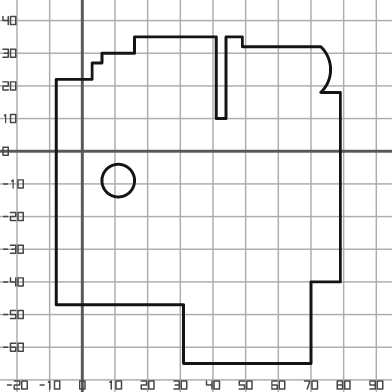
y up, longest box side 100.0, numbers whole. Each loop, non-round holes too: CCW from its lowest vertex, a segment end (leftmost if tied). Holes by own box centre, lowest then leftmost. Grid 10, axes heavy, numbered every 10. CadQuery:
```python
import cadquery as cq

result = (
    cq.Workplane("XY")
    .moveTo(31.0, -65.0)
    .lineTo(70.0, -65.0)
    .lineTo(70.0, -40.0)
    .lineTo(79.0, -40.0)
    .lineTo(79.0, 18.0)
    .lineTo(73.0, 18.0)
    .threePointArc((76.0, 25.0), (73.0, 32.0))
    .lineTo(49.0, 32.0)
    .lineTo(49.0, 35.0)
    .lineTo(44.0, 35.0)
    .lineTo(44.0, 10.0)
    .lineTo(41.0, 10.0)
    .lineTo(41.0, 35.0)
    .lineTo(16.0, 35.0)
    .lineTo(16.0, 30.0)
    .lineTo(6.0, 30.0)
    .lineTo(6.0, 27.0)
    .lineTo(3.0, 27.0)
    .lineTo(3.0, 22.0)
    .lineTo(-8.0, 22.0)
    .lineTo(-8.0, -47.0)
    .lineTo(31.0, -47.0)
    .close()
    .moveTo(11.0, -9.0)
    .circle(5.0)
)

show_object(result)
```